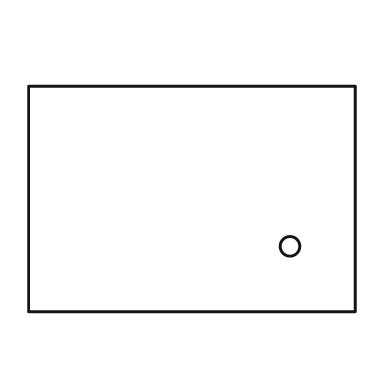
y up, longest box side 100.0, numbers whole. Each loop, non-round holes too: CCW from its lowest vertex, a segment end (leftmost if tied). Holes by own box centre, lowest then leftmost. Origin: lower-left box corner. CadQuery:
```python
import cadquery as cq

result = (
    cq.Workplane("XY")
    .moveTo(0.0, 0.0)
    .lineTo(100.0, 0.0)
    .lineTo(100.0, 69.0)
    .lineTo(0.0, 69.0)
    .close()
    .moveTo(80.0, 20.0)
    .circle(3.0)
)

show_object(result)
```